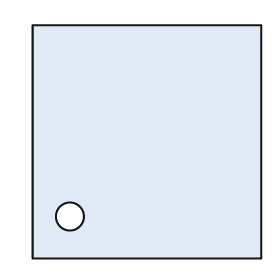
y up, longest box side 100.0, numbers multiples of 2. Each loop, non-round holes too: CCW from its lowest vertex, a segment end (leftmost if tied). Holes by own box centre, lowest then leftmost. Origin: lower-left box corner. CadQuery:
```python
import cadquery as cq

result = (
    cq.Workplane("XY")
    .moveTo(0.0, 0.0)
    .lineTo(98.0, 0.0)
    .lineTo(98.0, 100.0)
    .lineTo(0.0, 100.0)
    .close()
    .moveTo(16.0, 18.0)
    .circle(6.0)
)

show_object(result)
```